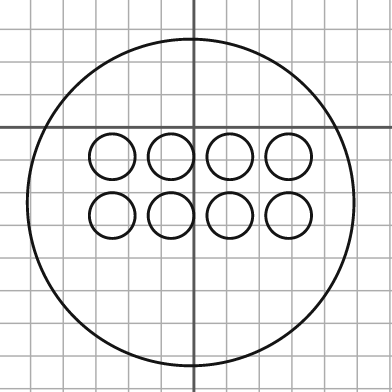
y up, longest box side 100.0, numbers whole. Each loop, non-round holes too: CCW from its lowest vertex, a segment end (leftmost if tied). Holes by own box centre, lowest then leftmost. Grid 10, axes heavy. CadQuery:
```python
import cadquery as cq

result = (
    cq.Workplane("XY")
    .moveTo(-1.0, -23.0)
    .circle(50.0)
    .moveTo(-25.0, -27.0)
    .circle(7.0)
    .moveTo(-7.0, -27.0)
    .circle(7.0)
    .moveTo(11.0, -27.0)
    .circle(7.0)
    .moveTo(29.0, -27.0)
    .circle(7.0)
    .moveTo(-25.0, -9.0)
    .circle(7.0)
    .moveTo(-7.0, -9.0)
    .circle(7.0)
    .moveTo(11.0, -9.0)
    .circle(7.0)
    .moveTo(29.0, -9.0)
    .circle(7.0)
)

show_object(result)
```